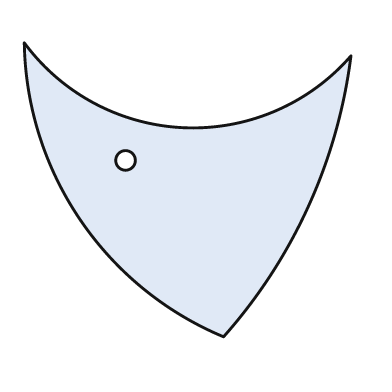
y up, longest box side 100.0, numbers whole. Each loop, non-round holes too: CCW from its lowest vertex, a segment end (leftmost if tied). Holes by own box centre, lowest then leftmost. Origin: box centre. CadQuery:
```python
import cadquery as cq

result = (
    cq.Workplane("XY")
    .moveTo(11.0, -45.0)
    .threePointArc((37.0, -5.0), (50.0, 41.0))
    .threePointArc((-1.0, 19.0), (-50.0, 45.0))
    .threePointArc((-33.0, -9.0), (11.0, -45.0))
    .close()
    .moveTo(-19.0, 9.0)
    .circle(3.0)
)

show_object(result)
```